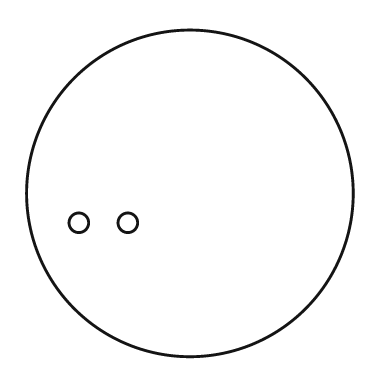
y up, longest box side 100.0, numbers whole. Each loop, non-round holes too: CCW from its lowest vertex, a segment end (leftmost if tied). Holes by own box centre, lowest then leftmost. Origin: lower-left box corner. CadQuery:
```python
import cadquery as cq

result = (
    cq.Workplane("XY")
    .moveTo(50.0, 50.0)
    .circle(50.0)
    .moveTo(16.0, 41.0)
    .circle(3.0)
    .moveTo(31.0, 41.0)
    .circle(3.0)
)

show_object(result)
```